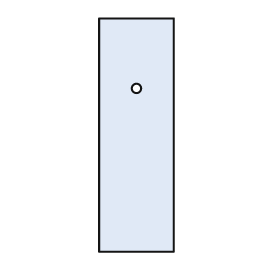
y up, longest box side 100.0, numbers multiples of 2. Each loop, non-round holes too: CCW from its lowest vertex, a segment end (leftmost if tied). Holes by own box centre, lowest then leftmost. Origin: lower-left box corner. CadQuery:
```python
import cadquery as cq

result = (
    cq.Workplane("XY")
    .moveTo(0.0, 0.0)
    .lineTo(32.0, 0.0)
    .lineTo(32.0, 100.0)
    .lineTo(0.0, 100.0)
    .close()
    .moveTo(16.0, 70.0)
    .circle(2.0)
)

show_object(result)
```